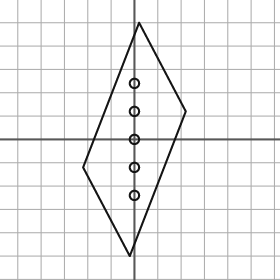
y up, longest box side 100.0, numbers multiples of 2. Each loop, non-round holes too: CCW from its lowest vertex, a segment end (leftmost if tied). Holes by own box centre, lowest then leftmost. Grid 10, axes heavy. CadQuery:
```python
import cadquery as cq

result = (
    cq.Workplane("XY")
    .moveTo(-2.0, -50.0)
    .lineTo(22.0, 12.0)
    .lineTo(2.0, 50.0)
    .lineTo(-22.0, -12.0)
    .close()
    .moveTo(0.0, -24.0)
    .circle(2.0)
    .moveTo(0.0, -12.0)
    .circle(2.0)
    .moveTo(0.0, 0.0)
    .circle(2.0)
    .moveTo(0.0, 12.0)
    .circle(2.0)
    .moveTo(0.0, 24.0)
    .circle(2.0)
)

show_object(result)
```